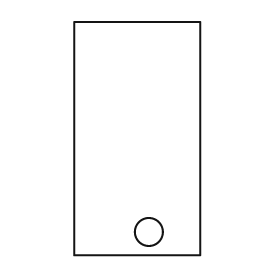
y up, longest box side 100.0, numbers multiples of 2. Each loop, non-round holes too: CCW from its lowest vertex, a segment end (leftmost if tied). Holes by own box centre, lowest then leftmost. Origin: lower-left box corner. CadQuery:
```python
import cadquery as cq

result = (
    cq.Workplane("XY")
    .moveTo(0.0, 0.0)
    .lineTo(54.0, 0.0)
    .lineTo(54.0, 100.0)
    .lineTo(0.0, 100.0)
    .close()
    .moveTo(32.0, 10.0)
    .circle(6.0)
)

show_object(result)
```